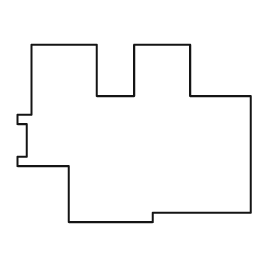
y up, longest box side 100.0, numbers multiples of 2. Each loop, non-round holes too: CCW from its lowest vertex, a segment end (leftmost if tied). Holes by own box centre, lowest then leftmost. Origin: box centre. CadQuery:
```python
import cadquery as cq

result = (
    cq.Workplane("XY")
    .moveTo(-28.0, -38.0)
    .lineTo(8.0, -38.0)
    .lineTo(8.0, -34.0)
    .lineTo(50.0, -34.0)
    .lineTo(50.0, 16.0)
    .lineTo(24.0, 16.0)
    .lineTo(24.0, 38.0)
    .lineTo(0.0, 38.0)
    .lineTo(0.0, 16.0)
    .lineTo(-16.0, 16.0)
    .lineTo(-16.0, 38.0)
    .lineTo(-44.0, 38.0)
    .lineTo(-44.0, 8.0)
    .lineTo(-50.0, 8.0)
    .lineTo(-50.0, 4.0)
    .lineTo(-46.0, 4.0)
    .lineTo(-46.0, -10.0)
    .lineTo(-50.0, -10.0)
    .lineTo(-50.0, -14.0)
    .lineTo(-28.0, -14.0)
    .close()
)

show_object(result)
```